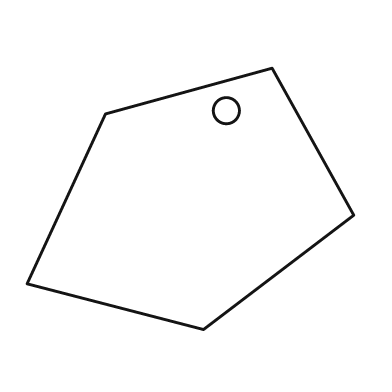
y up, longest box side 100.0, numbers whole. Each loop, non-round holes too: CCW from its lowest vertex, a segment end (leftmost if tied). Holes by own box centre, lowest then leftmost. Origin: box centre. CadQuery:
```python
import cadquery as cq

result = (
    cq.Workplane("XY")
    .moveTo(4.0, -40.0)
    .lineTo(50.0, -5.0)
    .lineTo(25.0, 40.0)
    .lineTo(-26.0, 26.0)
    .lineTo(-50.0, -26.0)
    .close()
    .moveTo(11.0, 27.0)
    .circle(4.0)
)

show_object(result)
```